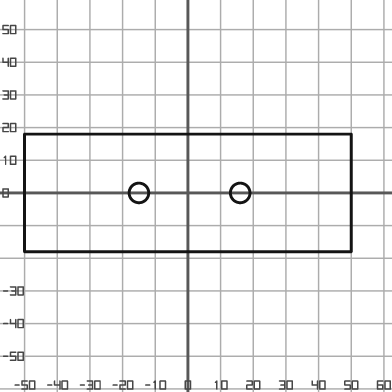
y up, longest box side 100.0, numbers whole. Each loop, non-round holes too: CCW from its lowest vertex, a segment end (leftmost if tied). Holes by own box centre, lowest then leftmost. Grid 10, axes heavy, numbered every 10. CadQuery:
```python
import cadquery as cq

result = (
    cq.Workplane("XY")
    .moveTo(-50.0, -18.0)
    .lineTo(50.0, -18.0)
    .lineTo(50.0, 18.0)
    .lineTo(-50.0, 18.0)
    .close()
    .moveTo(-15.0, 0.0)
    .circle(3.0)
    .moveTo(16.0, 0.0)
    .circle(3.0)
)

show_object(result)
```